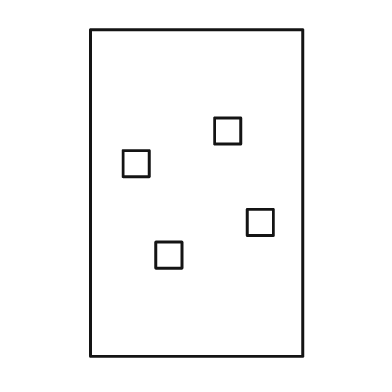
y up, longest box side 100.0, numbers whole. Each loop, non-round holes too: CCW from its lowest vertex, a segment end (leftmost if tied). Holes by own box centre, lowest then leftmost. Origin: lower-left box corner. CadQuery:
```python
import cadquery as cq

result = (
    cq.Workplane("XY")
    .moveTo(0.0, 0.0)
    .lineTo(65.0, 0.0)
    .lineTo(65.0, 100.0)
    .lineTo(0.0, 100.0)
    .close()
    .moveTo(20.0, 27.0)
    .lineTo(28.0, 27.0)
    .lineTo(28.0, 35.0)
    .lineTo(20.0, 35.0)
    .close()
    .moveTo(48.0, 37.0)
    .lineTo(56.0, 37.0)
    .lineTo(56.0, 45.0)
    .lineTo(48.0, 45.0)
    .close()
    .moveTo(10.0, 55.0)
    .lineTo(18.0, 55.0)
    .lineTo(18.0, 63.0)
    .lineTo(10.0, 63.0)
    .close()
    .moveTo(38.0, 65.0)
    .lineTo(46.0, 65.0)
    .lineTo(46.0, 73.0)
    .lineTo(38.0, 73.0)
    .close()
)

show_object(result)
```